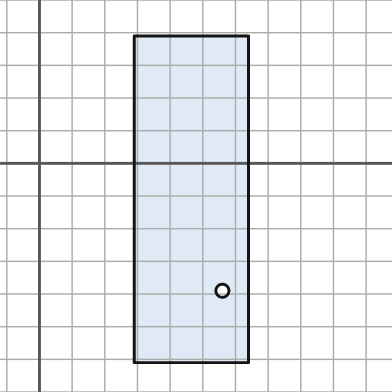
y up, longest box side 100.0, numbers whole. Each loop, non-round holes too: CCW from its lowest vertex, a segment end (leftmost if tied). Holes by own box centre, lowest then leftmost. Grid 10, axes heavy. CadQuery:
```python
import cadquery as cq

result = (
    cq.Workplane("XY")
    .moveTo(29.0, -61.0)
    .lineTo(64.0, -61.0)
    .lineTo(64.0, 39.0)
    .lineTo(29.0, 39.0)
    .close()
    .moveTo(56.0, -39.0)
    .circle(2.0)
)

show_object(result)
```